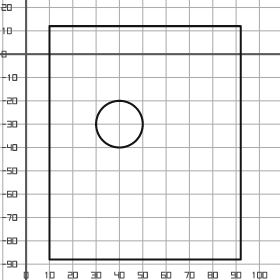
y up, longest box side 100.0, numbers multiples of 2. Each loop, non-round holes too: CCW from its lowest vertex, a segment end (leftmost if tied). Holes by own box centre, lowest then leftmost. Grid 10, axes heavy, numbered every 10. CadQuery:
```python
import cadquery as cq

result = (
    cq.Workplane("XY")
    .moveTo(10.0, -88.0)
    .lineTo(92.0, -88.0)
    .lineTo(92.0, 12.0)
    .lineTo(10.0, 12.0)
    .close()
    .moveTo(40.0, -30.0)
    .circle(10.0)
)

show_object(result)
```